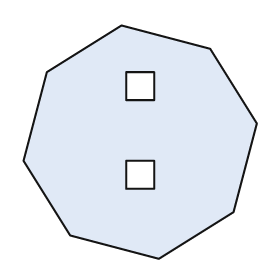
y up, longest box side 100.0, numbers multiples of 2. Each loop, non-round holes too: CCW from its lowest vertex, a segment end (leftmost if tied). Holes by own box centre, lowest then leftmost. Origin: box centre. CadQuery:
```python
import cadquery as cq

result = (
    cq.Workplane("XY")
    .moveTo(8.0, -50.0)
    .lineTo(40.0, -30.0)
    .lineTo(50.0, 8.0)
    .lineTo(30.0, 40.0)
    .lineTo(-8.0, 50.0)
    .lineTo(-40.0, 30.0)
    .lineTo(-50.0, -8.0)
    .lineTo(-30.0, -40.0)
    .close()
    .moveTo(-6.0, -20.0)
    .lineTo(6.0, -20.0)
    .lineTo(6.0, -8.0)
    .lineTo(-6.0, -8.0)
    .close()
    .moveTo(-6.0, 18.0)
    .lineTo(6.0, 18.0)
    .lineTo(6.0, 30.0)
    .lineTo(-6.0, 30.0)
    .close()
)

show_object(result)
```